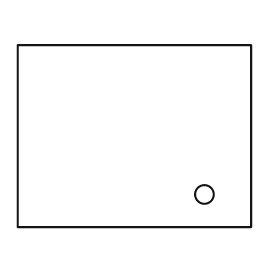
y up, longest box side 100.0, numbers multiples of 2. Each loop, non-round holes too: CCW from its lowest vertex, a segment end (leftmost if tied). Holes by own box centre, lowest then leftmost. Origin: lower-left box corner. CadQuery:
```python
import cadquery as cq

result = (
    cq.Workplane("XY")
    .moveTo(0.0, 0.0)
    .lineTo(100.0, 0.0)
    .lineTo(100.0, 78.0)
    .lineTo(0.0, 78.0)
    .close()
    .moveTo(80.0, 14.0)
    .circle(4.0)
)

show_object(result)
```